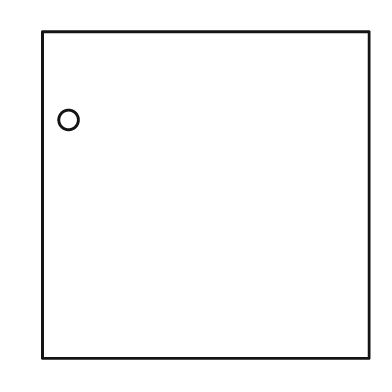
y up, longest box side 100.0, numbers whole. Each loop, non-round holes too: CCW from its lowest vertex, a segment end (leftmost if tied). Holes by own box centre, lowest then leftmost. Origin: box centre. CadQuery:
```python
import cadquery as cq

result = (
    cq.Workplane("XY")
    .moveTo(-50.0, -50.0)
    .lineTo(50.0, -50.0)
    .lineTo(50.0, 50.0)
    .lineTo(-50.0, 50.0)
    .close()
    .moveTo(-42.0, 23.0)
    .circle(3.0)
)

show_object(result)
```